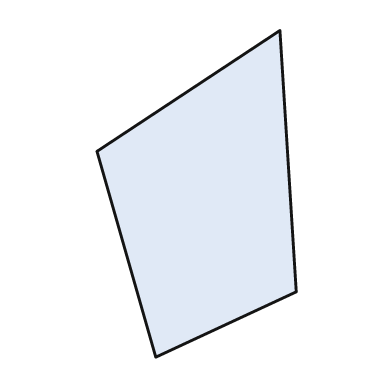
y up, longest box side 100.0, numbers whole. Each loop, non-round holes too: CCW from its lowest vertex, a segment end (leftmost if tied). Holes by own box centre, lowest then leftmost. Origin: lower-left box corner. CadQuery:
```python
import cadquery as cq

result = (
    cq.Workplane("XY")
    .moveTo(18.0, 0.0)
    .lineTo(61.0, 20.0)
    .lineTo(56.0, 100.0)
    .lineTo(0.0, 63.0)
    .close()
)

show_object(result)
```